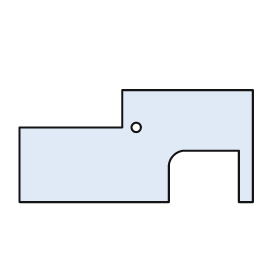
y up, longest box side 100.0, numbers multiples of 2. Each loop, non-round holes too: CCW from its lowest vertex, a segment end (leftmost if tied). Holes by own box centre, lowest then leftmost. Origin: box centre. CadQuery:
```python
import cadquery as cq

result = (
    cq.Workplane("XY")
    .moveTo(-50.0, -24.0)
    .lineTo(14.0, -24.0)
    .lineTo(14.0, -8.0)
    .threePointArc((16.0, -4.0), (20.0, -2.0))
    .lineTo(44.0, -2.0)
    .lineTo(44.0, -24.0)
    .lineTo(50.0, -24.0)
    .lineTo(50.0, 24.0)
    .lineTo(-6.0, 24.0)
    .lineTo(-6.0, 8.0)
    .lineTo(-50.0, 8.0)
    .close()
    .moveTo(0.0, 8.0)
    .circle(2.0)
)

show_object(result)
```